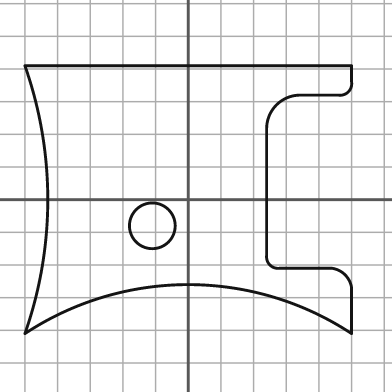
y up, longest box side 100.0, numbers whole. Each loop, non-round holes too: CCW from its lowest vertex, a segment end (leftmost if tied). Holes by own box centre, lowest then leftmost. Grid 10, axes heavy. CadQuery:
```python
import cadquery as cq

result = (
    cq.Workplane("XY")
    .moveTo(-50.0, -41.0)
    .threePointArc((0.0, -26.0), (50.0, -41.0))
    .lineTo(50.0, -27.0)
    .threePointArc((48.0, -23.0), (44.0, -21.0))
    .lineTo(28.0, -21.0)
    .threePointArc((25.0, -20.0), (24.0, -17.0))
    .lineTo(24.0, 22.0)
    .threePointArc((27.0, 29.0), (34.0, 32.0))
    .lineTo(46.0, 32.0)
    .threePointArc((49.0, 33.0), (50.0, 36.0))
    .lineTo(50.0, 41.0)
    .lineTo(-50.0, 41.0)
    .threePointArc((-43.0, 0.0), (-50.0, -41.0))
    .close()
    .moveTo(-11.0, -8.0)
    .circle(7.0)
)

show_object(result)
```